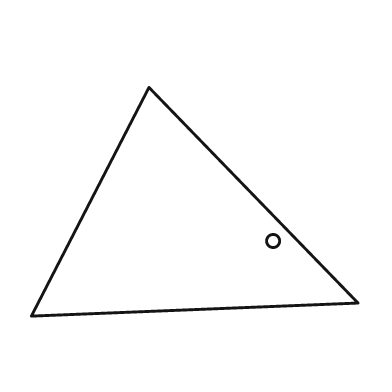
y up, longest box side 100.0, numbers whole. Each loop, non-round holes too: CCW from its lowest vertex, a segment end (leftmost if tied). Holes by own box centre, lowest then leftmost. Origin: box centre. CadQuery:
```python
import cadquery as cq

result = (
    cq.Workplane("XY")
    .moveTo(-50.0, -35.0)
    .lineTo(50.0, -31.0)
    .lineTo(-14.0, 35.0)
    .close()
    .moveTo(24.0, -12.0)
    .circle(2.0)
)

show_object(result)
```